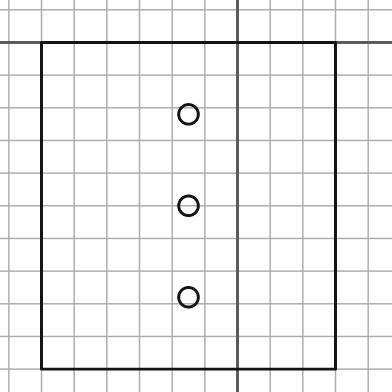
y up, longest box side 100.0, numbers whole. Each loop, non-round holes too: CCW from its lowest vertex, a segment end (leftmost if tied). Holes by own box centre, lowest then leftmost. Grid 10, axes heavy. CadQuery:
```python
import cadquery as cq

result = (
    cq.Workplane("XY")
    .moveTo(-60.0, -100.0)
    .lineTo(30.0, -100.0)
    .lineTo(30.0, 0.0)
    .lineTo(-60.0, 0.0)
    .close()
    .moveTo(-15.0, -78.0)
    .circle(3.0)
    .moveTo(-15.0, -50.0)
    .circle(3.0)
    .moveTo(-15.0, -22.0)
    .circle(3.0)
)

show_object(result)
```